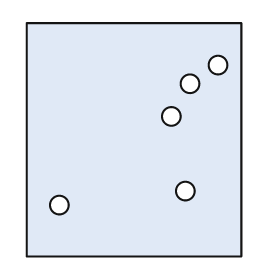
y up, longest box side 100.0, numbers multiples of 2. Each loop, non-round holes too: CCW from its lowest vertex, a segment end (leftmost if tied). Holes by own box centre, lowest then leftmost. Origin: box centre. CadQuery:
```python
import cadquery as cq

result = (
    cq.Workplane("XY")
    .moveTo(-46.0, -50.0)
    .lineTo(46.0, -50.0)
    .lineTo(46.0, 50.0)
    .lineTo(-46.0, 50.0)
    .close()
    .moveTo(-32.0, -28.0)
    .circle(4.0)
    .moveTo(22.0, -22.0)
    .circle(4.0)
    .moveTo(16.0, 10.0)
    .circle(4.0)
    .moveTo(24.0, 24.0)
    .circle(4.0)
    .moveTo(36.0, 32.0)
    .circle(4.0)
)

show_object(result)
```